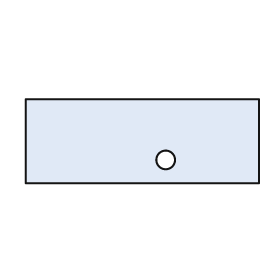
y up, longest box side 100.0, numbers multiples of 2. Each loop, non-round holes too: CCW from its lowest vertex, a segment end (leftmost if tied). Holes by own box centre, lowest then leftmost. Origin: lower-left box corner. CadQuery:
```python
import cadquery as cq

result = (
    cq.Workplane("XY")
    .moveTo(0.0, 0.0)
    .lineTo(100.0, 0.0)
    .lineTo(100.0, 36.0)
    .lineTo(0.0, 36.0)
    .close()
    .moveTo(60.0, 10.0)
    .circle(4.0)
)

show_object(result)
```